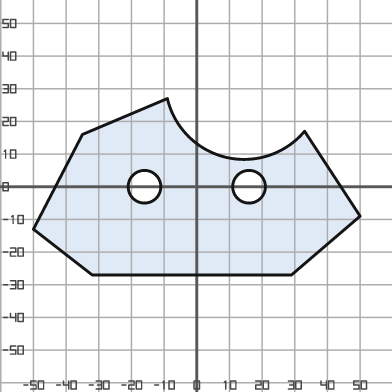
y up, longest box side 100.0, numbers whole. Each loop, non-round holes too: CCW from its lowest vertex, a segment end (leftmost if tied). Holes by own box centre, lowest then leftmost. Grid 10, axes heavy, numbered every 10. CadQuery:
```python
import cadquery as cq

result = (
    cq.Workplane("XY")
    .moveTo(-32.0, -27.0)
    .lineTo(29.0, -27.0)
    .lineTo(50.0, -9.0)
    .lineTo(33.0, 17.0)
    .threePointArc((9.0, 9.0), (-9.0, 27.0))
    .lineTo(-35.0, 16.0)
    .lineTo(-50.0, -13.0)
    .close()
    .moveTo(-16.0, 0.0)
    .circle(5.0)
    .moveTo(16.0, 0.0)
    .circle(5.0)
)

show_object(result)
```